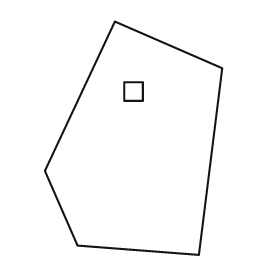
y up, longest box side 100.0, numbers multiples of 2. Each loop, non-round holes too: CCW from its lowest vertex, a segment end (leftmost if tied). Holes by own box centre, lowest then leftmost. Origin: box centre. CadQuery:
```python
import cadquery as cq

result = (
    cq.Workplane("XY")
    .moveTo(28.0, -50.0)
    .lineTo(38.0, 30.0)
    .lineTo(-8.0, 50.0)
    .lineTo(-38.0, -14.0)
    .lineTo(-24.0, -46.0)
    .close()
    .moveTo(-4.0, 16.0)
    .lineTo(4.0, 16.0)
    .lineTo(4.0, 24.0)
    .lineTo(-4.0, 24.0)
    .close()
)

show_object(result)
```